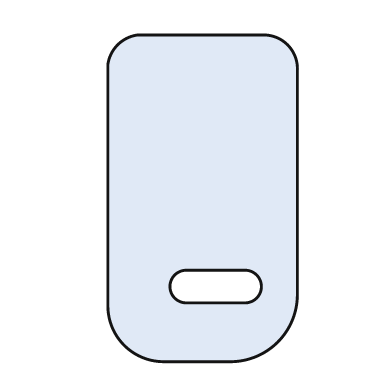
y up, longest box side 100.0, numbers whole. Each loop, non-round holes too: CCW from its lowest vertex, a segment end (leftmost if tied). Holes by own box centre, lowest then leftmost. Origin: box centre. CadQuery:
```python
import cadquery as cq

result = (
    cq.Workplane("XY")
    .moveTo(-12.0, -50.0)
    .lineTo(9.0, -50.0)
    .threePointArc((23.0, -44.0), (29.0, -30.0))
    .lineTo(29.0, 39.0)
    .threePointArc((26.0, 47.0), (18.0, 50.0))
    .lineTo(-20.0, 50.0)
    .threePointArc((-26.0, 47.0), (-29.0, 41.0))
    .lineTo(-29.0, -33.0)
    .threePointArc((-24.0, -45.0), (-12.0, -50.0))
    .close()
    .moveTo(-5.0, -32.0)
    .lineTo(13.0, -32.0)
    .threePointArc((18.0, -27.0), (13.0, -22.0))
    .lineTo(-5.0, -22.0)
    .threePointArc((-10.0, -27.0), (-5.0, -32.0))
    .close()
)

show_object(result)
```